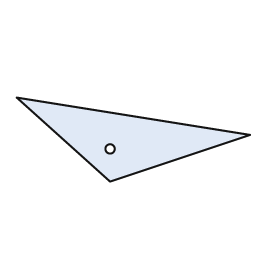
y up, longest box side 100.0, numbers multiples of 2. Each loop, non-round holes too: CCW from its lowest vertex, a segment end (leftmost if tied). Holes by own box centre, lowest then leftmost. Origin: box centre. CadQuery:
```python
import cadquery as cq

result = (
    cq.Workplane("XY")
    .moveTo(-10.0, -18.0)
    .lineTo(50.0, 2.0)
    .lineTo(-50.0, 18.0)
    .close()
    .moveTo(-10.0, -4.0)
    .circle(2.0)
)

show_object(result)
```